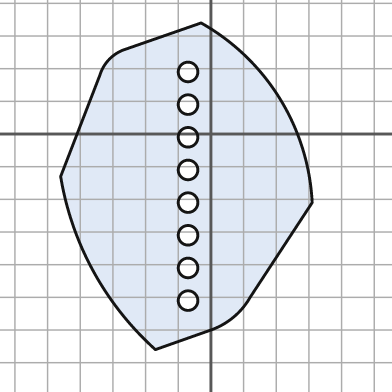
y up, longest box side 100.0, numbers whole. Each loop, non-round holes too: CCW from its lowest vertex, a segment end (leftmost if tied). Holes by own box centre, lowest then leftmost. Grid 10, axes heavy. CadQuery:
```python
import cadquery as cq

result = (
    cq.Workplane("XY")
    .moveTo(-17.0, -66.0)
    .lineTo(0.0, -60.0)
    .threePointArc((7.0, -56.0), (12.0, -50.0))
    .lineTo(31.0, -21.0)
    .threePointArc((21.0, 11.0), (-3.0, 34.0))
    .lineTo(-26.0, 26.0)
    .threePointArc((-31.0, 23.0), (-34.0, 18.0))
    .lineTo(-46.0, -13.0)
    .threePointArc((-36.0, -42.0), (-17.0, -66.0))
    .close()
    .moveTo(-7.0, -51.0)
    .circle(3.0)
    .moveTo(-7.0, -41.0)
    .circle(3.0)
    .moveTo(-7.0, -31.0)
    .circle(3.0)
    .moveTo(-7.0, -21.0)
    .circle(3.0)
    .moveTo(-7.0, -11.0)
    .circle(3.0)
    .moveTo(-7.0, -1.0)
    .circle(3.0)
    .moveTo(-7.0, 9.0)
    .circle(3.0)
    .moveTo(-7.0, 19.0)
    .circle(3.0)
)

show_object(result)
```